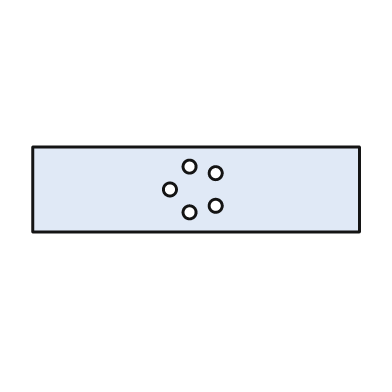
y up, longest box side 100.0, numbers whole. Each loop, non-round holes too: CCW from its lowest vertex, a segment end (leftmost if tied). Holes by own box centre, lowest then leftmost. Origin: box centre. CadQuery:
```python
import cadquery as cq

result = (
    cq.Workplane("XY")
    .moveTo(-50.0, -13.0)
    .lineTo(50.0, -13.0)
    .lineTo(50.0, 13.0)
    .lineTo(-50.0, 13.0)
    .close()
    .moveTo(-2.0, -7.0)
    .circle(2.0)
    .moveTo(6.0, -5.0)
    .circle(2.0)
    .moveTo(-8.0, 0.0)
    .circle(2.0)
    .moveTo(6.0, 5.0)
    .circle(2.0)
    .moveTo(-2.0, 7.0)
    .circle(2.0)
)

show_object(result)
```